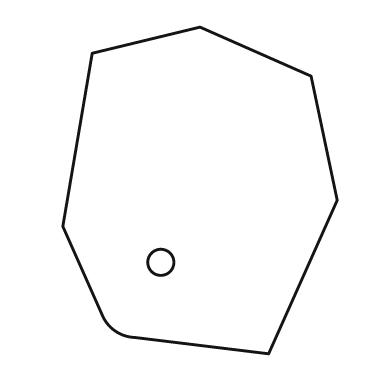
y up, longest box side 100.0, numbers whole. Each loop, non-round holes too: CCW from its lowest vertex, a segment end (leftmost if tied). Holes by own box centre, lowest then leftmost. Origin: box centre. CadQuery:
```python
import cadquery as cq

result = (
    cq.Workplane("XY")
    .moveTo(21.0, -50.0)
    .lineTo(42.0, -3.0)
    .lineTo(34.0, 35.0)
    .lineTo(0.0, 50.0)
    .lineTo(-33.0, 42.0)
    .lineTo(-42.0, -11.0)
    .lineTo(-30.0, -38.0)
    .threePointArc((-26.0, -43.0), (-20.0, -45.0))
    .close()
    .moveTo(-12.0, -22.0)
    .circle(4.0)
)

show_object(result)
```